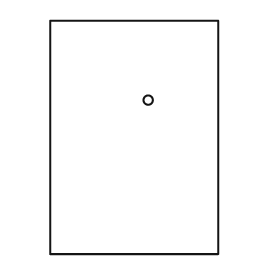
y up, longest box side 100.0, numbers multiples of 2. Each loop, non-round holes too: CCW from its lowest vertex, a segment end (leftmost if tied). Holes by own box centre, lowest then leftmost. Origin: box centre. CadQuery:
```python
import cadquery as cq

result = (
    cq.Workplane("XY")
    .moveTo(-36.0, -50.0)
    .lineTo(36.0, -50.0)
    .lineTo(36.0, 50.0)
    .lineTo(-36.0, 50.0)
    .close()
    .moveTo(6.0, 16.0)
    .circle(2.0)
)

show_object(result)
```